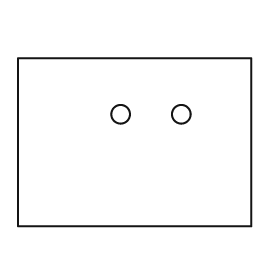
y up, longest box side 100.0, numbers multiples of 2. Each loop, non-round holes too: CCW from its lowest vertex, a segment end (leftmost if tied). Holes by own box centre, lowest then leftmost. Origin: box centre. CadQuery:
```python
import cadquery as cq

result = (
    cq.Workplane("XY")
    .moveTo(-50.0, -36.0)
    .lineTo(50.0, -36.0)
    .lineTo(50.0, 36.0)
    .lineTo(-50.0, 36.0)
    .close()
    .moveTo(-6.0, 12.0)
    .circle(4.0)
    .moveTo(20.0, 12.0)
    .circle(4.0)
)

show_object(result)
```